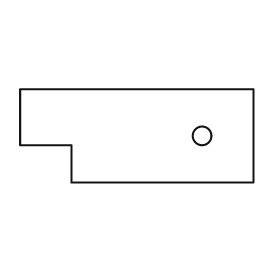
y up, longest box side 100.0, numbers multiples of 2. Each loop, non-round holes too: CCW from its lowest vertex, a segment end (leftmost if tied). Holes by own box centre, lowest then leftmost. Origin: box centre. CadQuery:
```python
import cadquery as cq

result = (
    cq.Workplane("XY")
    .moveTo(-28.0, -20.0)
    .lineTo(50.0, -20.0)
    .lineTo(50.0, 20.0)
    .lineTo(-50.0, 20.0)
    .lineTo(-50.0, -4.0)
    .lineTo(-28.0, -4.0)
    .close()
    .moveTo(28.0, 0.0)
    .circle(4.0)
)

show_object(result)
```